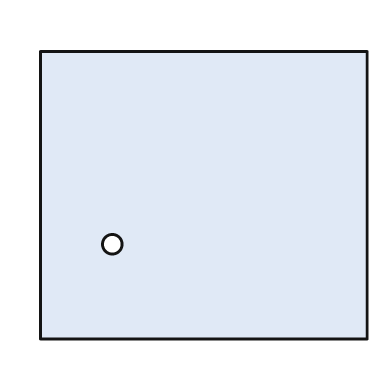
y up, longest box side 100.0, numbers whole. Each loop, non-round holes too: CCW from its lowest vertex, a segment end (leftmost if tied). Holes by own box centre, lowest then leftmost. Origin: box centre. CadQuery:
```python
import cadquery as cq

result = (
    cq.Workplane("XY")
    .moveTo(-50.0, -44.0)
    .lineTo(50.0, -44.0)
    .lineTo(50.0, 44.0)
    .lineTo(-50.0, 44.0)
    .close()
    .moveTo(-28.0, -15.0)
    .circle(3.0)
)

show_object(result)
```